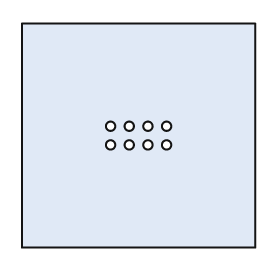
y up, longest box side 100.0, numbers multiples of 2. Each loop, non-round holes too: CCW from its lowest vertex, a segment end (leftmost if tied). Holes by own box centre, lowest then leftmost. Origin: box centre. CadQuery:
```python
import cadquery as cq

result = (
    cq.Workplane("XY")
    .moveTo(-50.0, -48.0)
    .lineTo(50.0, -48.0)
    .lineTo(50.0, 48.0)
    .lineTo(-50.0, 48.0)
    .close()
    .moveTo(-12.0, -4.0)
    .circle(2.0)
    .moveTo(-4.0, -4.0)
    .circle(2.0)
    .moveTo(4.0, -4.0)
    .circle(2.0)
    .moveTo(12.0, -4.0)
    .circle(2.0)
    .moveTo(-12.0, 4.0)
    .circle(2.0)
    .moveTo(-4.0, 4.0)
    .circle(2.0)
    .moveTo(4.0, 4.0)
    .circle(2.0)
    .moveTo(12.0, 4.0)
    .circle(2.0)
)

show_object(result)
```